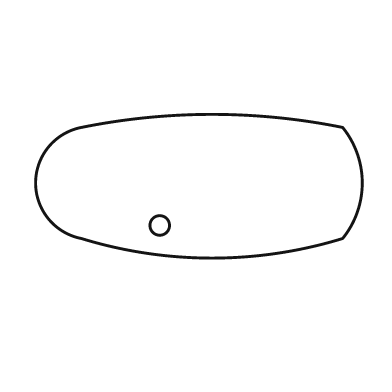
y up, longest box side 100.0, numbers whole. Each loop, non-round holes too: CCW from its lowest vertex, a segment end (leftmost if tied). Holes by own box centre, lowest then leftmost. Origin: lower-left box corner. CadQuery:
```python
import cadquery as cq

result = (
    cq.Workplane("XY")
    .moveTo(14.0, 6.0)
    .threePointArc((54.0, 0.0), (94.0, 6.0))
    .threePointArc((100.0, 23.0), (94.0, 40.0))
    .threePointArc((54.0, 44.0), (14.0, 40.0))
    .threePointArc((0.0, 23.0), (14.0, 6.0))
    .close()
    .moveTo(38.0, 10.0)
    .circle(3.0)
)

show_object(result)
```